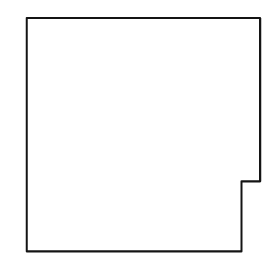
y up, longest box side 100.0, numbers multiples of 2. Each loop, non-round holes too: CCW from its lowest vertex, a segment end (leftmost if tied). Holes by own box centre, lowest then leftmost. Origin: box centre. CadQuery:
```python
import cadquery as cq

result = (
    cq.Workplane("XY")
    .moveTo(-50.0, -50.0)
    .lineTo(42.0, -50.0)
    .lineTo(42.0, -20.0)
    .lineTo(50.0, -20.0)
    .lineTo(50.0, 50.0)
    .lineTo(-50.0, 50.0)
    .close()
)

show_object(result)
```